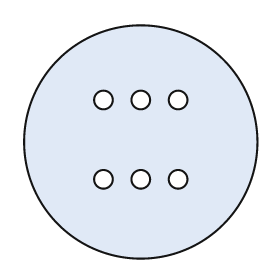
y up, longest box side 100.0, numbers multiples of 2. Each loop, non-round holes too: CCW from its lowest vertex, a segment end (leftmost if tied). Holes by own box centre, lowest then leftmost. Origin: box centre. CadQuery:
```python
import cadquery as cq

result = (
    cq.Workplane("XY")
    .moveTo(0.0, 0.0)
    .circle(50.0)
    .moveTo(-16.0, -16.0)
    .circle(4.0)
    .moveTo(0.0, -16.0)
    .circle(4.0)
    .moveTo(16.0, -16.0)
    .circle(4.0)
    .moveTo(-16.0, 18.0)
    .circle(4.0)
    .moveTo(0.0, 18.0)
    .circle(4.0)
    .moveTo(16.0, 18.0)
    .circle(4.0)
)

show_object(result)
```